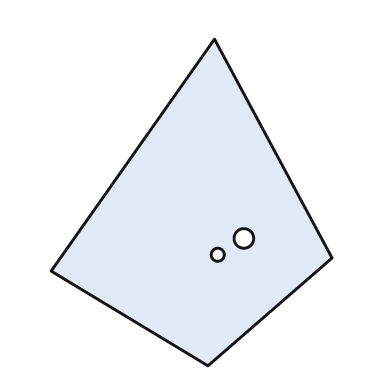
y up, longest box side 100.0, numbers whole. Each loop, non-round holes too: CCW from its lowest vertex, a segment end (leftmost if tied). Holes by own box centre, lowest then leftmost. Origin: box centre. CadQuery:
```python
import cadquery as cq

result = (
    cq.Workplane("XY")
    .moveTo(5.0, -50.0)
    .lineTo(43.0, -17.0)
    .lineTo(7.0, 50.0)
    .lineTo(-43.0, -21.0)
    .close()
    .moveTo(8.0, -16.0)
    .circle(2.0)
    .moveTo(16.0, -11.0)
    .circle(3.0)
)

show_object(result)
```